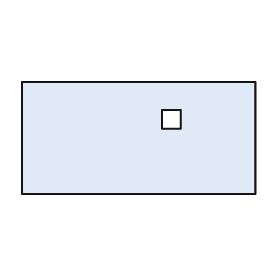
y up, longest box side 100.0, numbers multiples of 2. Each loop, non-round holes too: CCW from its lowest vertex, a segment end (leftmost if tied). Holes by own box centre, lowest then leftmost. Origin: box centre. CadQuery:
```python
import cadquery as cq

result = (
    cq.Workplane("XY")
    .moveTo(-50.0, -24.0)
    .lineTo(50.0, -24.0)
    .lineTo(50.0, 24.0)
    .lineTo(-50.0, 24.0)
    .close()
    .moveTo(10.0, 4.0)
    .lineTo(18.0, 4.0)
    .lineTo(18.0, 12.0)
    .lineTo(10.0, 12.0)
    .close()
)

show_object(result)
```